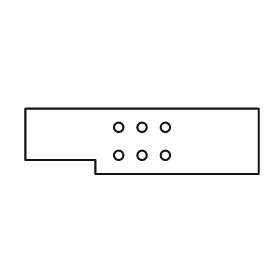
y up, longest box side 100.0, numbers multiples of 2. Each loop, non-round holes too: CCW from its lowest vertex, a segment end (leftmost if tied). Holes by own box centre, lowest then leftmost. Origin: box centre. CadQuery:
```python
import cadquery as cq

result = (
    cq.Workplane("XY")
    .moveTo(-20.0, -14.0)
    .lineTo(50.0, -14.0)
    .lineTo(50.0, 14.0)
    .lineTo(-50.0, 14.0)
    .lineTo(-50.0, -8.0)
    .lineTo(-20.0, -8.0)
    .close()
    .moveTo(-10.0, -6.0)
    .circle(2.0)
    .moveTo(0.0, -6.0)
    .circle(2.0)
    .moveTo(10.0, -6.0)
    .circle(2.0)
    .moveTo(-10.0, 6.0)
    .circle(2.0)
    .moveTo(0.0, 6.0)
    .circle(2.0)
    .moveTo(10.0, 6.0)
    .circle(2.0)
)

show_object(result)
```